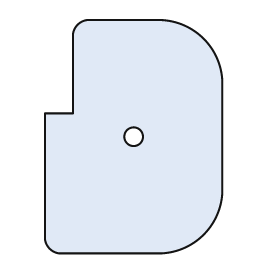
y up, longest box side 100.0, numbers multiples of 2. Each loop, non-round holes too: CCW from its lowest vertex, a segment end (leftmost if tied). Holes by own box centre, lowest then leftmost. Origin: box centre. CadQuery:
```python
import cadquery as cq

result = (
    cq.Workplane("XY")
    .moveTo(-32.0, -50.0)
    .lineTo(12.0, -50.0)
    .threePointArc((30.0, -42.0), (38.0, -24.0))
    .lineTo(38.0, 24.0)
    .threePointArc((30.0, 42.0), (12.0, 50.0))
    .lineTo(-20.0, 50.0)
    .threePointArc((-24.0, 48.0), (-26.0, 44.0))
    .lineTo(-26.0, 10.0)
    .lineTo(-38.0, 10.0)
    .lineTo(-38.0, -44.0)
    .threePointArc((-36.0, -48.0), (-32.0, -50.0))
    .close()
    .moveTo(0.0, 0.0)
    .circle(4.0)
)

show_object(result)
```